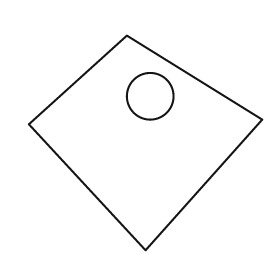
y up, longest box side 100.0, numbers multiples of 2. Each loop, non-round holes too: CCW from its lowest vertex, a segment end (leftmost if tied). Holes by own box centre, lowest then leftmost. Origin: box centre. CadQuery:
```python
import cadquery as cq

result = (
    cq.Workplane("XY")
    .moveTo(0.0, -46.0)
    .lineTo(50.0, 10.0)
    .lineTo(-8.0, 46.0)
    .lineTo(-50.0, 8.0)
    .close()
    .moveTo(2.0, 20.0)
    .circle(10.0)
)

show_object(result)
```